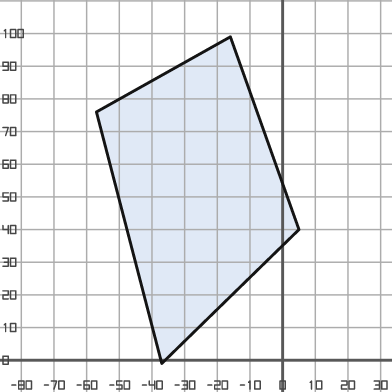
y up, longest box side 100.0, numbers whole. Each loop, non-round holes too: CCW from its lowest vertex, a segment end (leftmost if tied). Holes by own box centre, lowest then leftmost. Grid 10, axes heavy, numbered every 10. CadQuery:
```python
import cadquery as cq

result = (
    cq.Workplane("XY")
    .moveTo(-37.0, -1.0)
    .lineTo(5.0, 40.0)
    .lineTo(-16.0, 99.0)
    .lineTo(-57.0, 76.0)
    .close()
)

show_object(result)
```